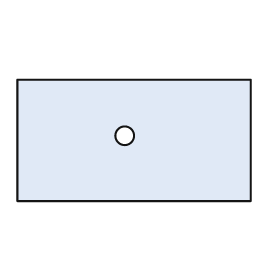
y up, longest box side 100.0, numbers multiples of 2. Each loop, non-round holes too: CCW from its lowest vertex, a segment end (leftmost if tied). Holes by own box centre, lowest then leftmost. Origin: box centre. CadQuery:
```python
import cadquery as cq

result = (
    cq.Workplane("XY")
    .moveTo(-50.0, -26.0)
    .lineTo(50.0, -26.0)
    .lineTo(50.0, 26.0)
    .lineTo(-50.0, 26.0)
    .close()
    .moveTo(-4.0, 2.0)
    .circle(4.0)
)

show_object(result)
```